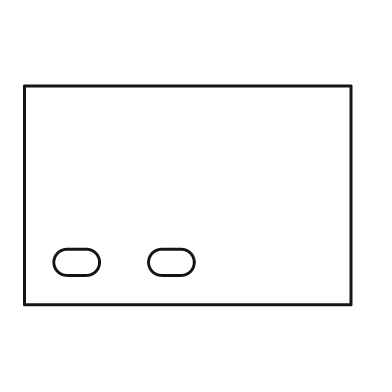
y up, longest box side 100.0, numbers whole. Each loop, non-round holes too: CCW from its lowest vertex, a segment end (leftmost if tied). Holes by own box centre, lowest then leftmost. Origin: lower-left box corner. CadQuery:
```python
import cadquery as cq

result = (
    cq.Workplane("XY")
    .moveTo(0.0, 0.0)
    .lineTo(100.0, 0.0)
    .lineTo(100.0, 67.0)
    .lineTo(0.0, 67.0)
    .close()
    .moveTo(13.0, 9.0)
    .lineTo(19.0, 9.0)
    .threePointArc((23.0, 13.0), (19.0, 17.0))
    .lineTo(13.0, 17.0)
    .threePointArc((9.0, 13.0), (13.0, 9.0))
    .close()
    .moveTo(42.0, 9.0)
    .lineTo(48.0, 9.0)
    .threePointArc((52.0, 13.0), (48.0, 17.0))
    .lineTo(42.0, 17.0)
    .threePointArc((38.0, 13.0), (42.0, 9.0))
    .close()
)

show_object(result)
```